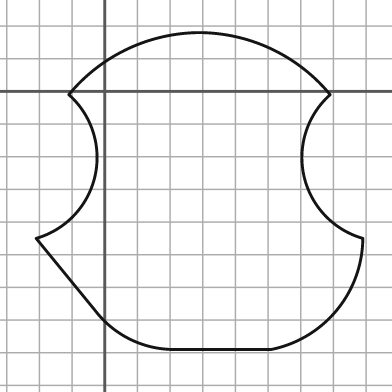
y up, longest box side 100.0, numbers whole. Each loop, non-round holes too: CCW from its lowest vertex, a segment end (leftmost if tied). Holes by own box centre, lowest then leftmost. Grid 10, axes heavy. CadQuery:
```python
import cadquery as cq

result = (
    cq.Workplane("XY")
    .moveTo(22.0, -79.0)
    .lineTo(51.0, -79.0)
    .threePointArc((71.0, -67.0), (79.0, -45.0))
    .threePointArc((61.0, -26.0), (69.0, -1.0))
    .threePointArc((51.0, 13.0), (29.0, 18.0))
    .threePointArc((7.0, 13.0), (-11.0, -1.0))
    .threePointArc((-3.0, -26.0), (-21.0, -45.0))
    .lineTo(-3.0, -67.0)
    .threePointArc((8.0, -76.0), (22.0, -79.0))
    .close()
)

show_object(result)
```